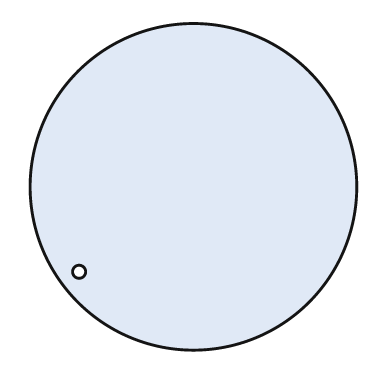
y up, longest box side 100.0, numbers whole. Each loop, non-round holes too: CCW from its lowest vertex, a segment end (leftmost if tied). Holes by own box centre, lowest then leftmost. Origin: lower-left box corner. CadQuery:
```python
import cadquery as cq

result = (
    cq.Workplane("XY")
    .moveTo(50.0, 50.0)
    .circle(50.0)
    .moveTo(15.0, 24.0)
    .circle(2.0)
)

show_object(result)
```